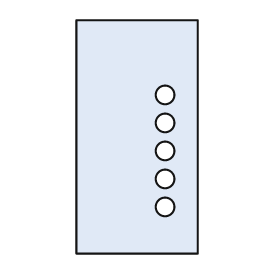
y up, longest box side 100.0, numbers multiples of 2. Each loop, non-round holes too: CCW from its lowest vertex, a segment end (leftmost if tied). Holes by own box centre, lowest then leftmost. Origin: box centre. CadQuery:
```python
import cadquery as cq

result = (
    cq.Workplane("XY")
    .moveTo(-26.0, -50.0)
    .lineTo(26.0, -50.0)
    .lineTo(26.0, 50.0)
    .lineTo(-26.0, 50.0)
    .close()
    .moveTo(12.0, -30.0)
    .circle(4.0)
    .moveTo(12.0, -18.0)
    .circle(4.0)
    .moveTo(12.0, -6.0)
    .circle(4.0)
    .moveTo(12.0, 6.0)
    .circle(4.0)
    .moveTo(12.0, 18.0)
    .circle(4.0)
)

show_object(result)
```